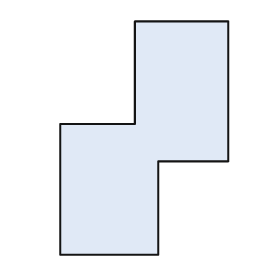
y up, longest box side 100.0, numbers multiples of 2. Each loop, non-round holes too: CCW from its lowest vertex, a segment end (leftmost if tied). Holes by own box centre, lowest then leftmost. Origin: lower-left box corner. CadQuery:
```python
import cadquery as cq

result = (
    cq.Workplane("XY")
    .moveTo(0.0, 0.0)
    .lineTo(42.0, 0.0)
    .lineTo(42.0, 40.0)
    .lineTo(72.0, 40.0)
    .lineTo(72.0, 100.0)
    .lineTo(32.0, 100.0)
    .lineTo(32.0, 56.0)
    .lineTo(0.0, 56.0)
    .close()
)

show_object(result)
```